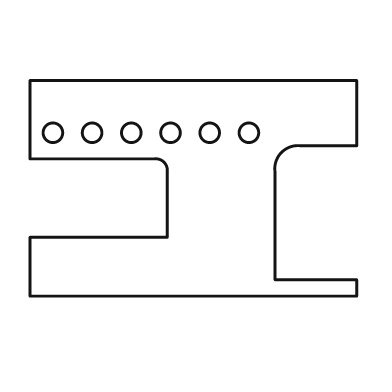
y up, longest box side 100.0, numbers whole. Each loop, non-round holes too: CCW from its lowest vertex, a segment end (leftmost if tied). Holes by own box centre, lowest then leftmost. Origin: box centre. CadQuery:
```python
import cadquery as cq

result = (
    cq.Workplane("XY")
    .moveTo(-50.0, -33.0)
    .lineTo(50.0, -33.0)
    .lineTo(50.0, -28.0)
    .lineTo(25.0, -28.0)
    .lineTo(25.0, 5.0)
    .threePointArc((27.0, 11.0), (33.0, 13.0))
    .lineTo(50.0, 13.0)
    .lineTo(50.0, 33.0)
    .lineTo(-50.0, 33.0)
    .lineTo(-50.0, 9.0)
    .lineTo(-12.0, 9.0)
    .threePointArc((-9.0, 8.0), (-8.0, 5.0))
    .lineTo(-8.0, -15.0)
    .lineTo(-50.0, -15.0)
    .close()
    .moveTo(-43.0, 17.0)
    .circle(3.0)
    .moveTo(-31.0, 17.0)
    .circle(3.0)
    .moveTo(-19.0, 17.0)
    .circle(3.0)
    .moveTo(-7.0, 17.0)
    .circle(3.0)
    .moveTo(5.0, 17.0)
    .circle(3.0)
    .moveTo(17.0, 17.0)
    .circle(3.0)
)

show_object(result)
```